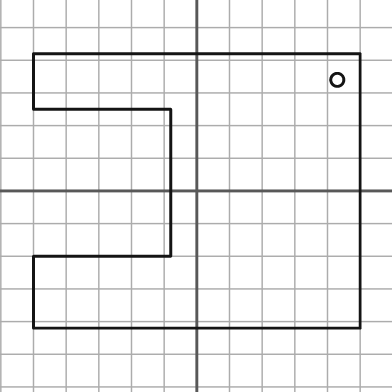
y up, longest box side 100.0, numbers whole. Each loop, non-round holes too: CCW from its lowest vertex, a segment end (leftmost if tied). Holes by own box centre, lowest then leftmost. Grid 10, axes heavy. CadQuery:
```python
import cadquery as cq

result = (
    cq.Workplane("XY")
    .moveTo(-50.0, -42.0)
    .lineTo(50.0, -42.0)
    .lineTo(50.0, 42.0)
    .lineTo(-50.0, 42.0)
    .lineTo(-50.0, 25.0)
    .lineTo(-8.0, 25.0)
    .lineTo(-8.0, -20.0)
    .lineTo(-50.0, -20.0)
    .close()
    .moveTo(43.0, 34.0)
    .circle(2.0)
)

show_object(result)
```